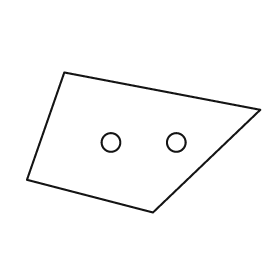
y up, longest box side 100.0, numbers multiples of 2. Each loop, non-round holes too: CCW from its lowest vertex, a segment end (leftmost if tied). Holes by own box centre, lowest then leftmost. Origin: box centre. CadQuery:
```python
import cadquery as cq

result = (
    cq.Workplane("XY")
    .moveTo(4.0, -30.0)
    .lineTo(50.0, 14.0)
    .lineTo(-34.0, 30.0)
    .lineTo(-50.0, -16.0)
    .close()
    .moveTo(-14.0, 0.0)
    .circle(4.0)
    .moveTo(14.0, 0.0)
    .circle(4.0)
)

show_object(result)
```